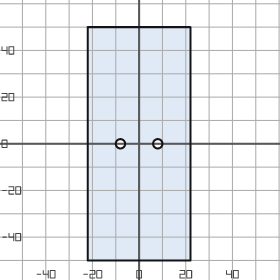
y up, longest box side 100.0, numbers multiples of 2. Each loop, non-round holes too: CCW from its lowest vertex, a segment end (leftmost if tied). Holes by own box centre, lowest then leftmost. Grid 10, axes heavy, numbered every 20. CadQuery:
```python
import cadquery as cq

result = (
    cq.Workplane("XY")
    .moveTo(-22.0, -50.0)
    .lineTo(22.0, -50.0)
    .lineTo(22.0, 50.0)
    .lineTo(-22.0, 50.0)
    .close()
    .moveTo(-8.0, 0.0)
    .circle(2.0)
    .moveTo(8.0, 0.0)
    .circle(2.0)
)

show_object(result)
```